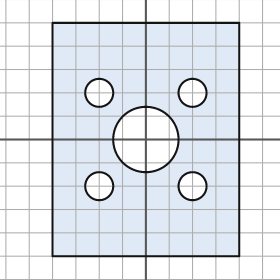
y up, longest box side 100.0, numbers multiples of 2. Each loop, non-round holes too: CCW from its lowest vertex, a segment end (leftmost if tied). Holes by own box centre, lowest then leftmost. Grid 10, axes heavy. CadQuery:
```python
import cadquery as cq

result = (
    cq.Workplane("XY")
    .moveTo(-40.0, -50.0)
    .lineTo(40.0, -50.0)
    .lineTo(40.0, 50.0)
    .lineTo(-40.0, 50.0)
    .close()
    .moveTo(-20.0, -20.0)
    .circle(6.0)
    .moveTo(20.0, -20.0)
    .circle(6.0)
    .moveTo(0.0, 0.0)
    .circle(14.0)
    .moveTo(-20.0, 20.0)
    .circle(6.0)
    .moveTo(20.0, 20.0)
    .circle(6.0)
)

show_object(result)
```